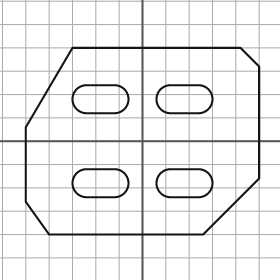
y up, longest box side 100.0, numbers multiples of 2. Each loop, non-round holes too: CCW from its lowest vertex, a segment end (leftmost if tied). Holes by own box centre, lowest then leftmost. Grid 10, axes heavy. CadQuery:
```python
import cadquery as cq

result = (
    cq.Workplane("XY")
    .moveTo(-40.0, -40.0)
    .lineTo(26.0, -40.0)
    .lineTo(50.0, -16.0)
    .lineTo(50.0, 32.0)
    .lineTo(42.0, 40.0)
    .lineTo(-30.0, 40.0)
    .lineTo(-50.0, 6.0)
    .lineTo(-50.0, -26.0)
    .close()
    .moveTo(-24.0, -24.0)
    .lineTo(-12.0, -24.0)
    .threePointArc((-6.0, -18.0), (-12.0, -12.0))
    .lineTo(-24.0, -12.0)
    .threePointArc((-30.0, -18.0), (-24.0, -24.0))
    .close()
    .moveTo(12.0, -24.0)
    .lineTo(24.0, -24.0)
    .threePointArc((30.0, -18.0), (24.0, -12.0))
    .lineTo(12.0, -12.0)
    .threePointArc((6.0, -18.0), (12.0, -24.0))
    .close()
    .moveTo(-24.0, 12.0)
    .lineTo(-12.0, 12.0)
    .threePointArc((-6.0, 18.0), (-12.0, 24.0))
    .lineTo(-24.0, 24.0)
    .threePointArc((-30.0, 18.0), (-24.0, 12.0))
    .close()
    .moveTo(12.0, 12.0)
    .lineTo(24.0, 12.0)
    .threePointArc((30.0, 18.0), (24.0, 24.0))
    .lineTo(12.0, 24.0)
    .threePointArc((6.0, 18.0), (12.0, 12.0))
    .close()
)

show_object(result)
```